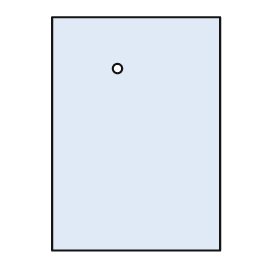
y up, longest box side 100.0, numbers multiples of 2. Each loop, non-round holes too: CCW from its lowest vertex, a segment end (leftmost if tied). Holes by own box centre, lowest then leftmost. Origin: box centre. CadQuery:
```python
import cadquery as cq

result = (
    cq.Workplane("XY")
    .moveTo(-36.0, -50.0)
    .lineTo(36.0, -50.0)
    .lineTo(36.0, 50.0)
    .lineTo(-36.0, 50.0)
    .close()
    .moveTo(-8.0, 28.0)
    .circle(2.0)
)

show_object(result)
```